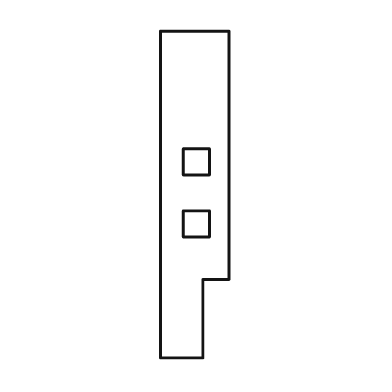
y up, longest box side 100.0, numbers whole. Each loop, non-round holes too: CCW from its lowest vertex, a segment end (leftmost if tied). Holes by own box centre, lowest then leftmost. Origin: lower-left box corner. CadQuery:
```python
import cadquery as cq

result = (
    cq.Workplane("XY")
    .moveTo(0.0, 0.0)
    .lineTo(13.0, 0.0)
    .lineTo(13.0, 24.0)
    .lineTo(21.0, 24.0)
    .lineTo(21.0, 100.0)
    .lineTo(0.0, 100.0)
    .close()
    .moveTo(7.0, 37.0)
    .lineTo(15.0, 37.0)
    .lineTo(15.0, 45.0)
    .lineTo(7.0, 45.0)
    .close()
    .moveTo(7.0, 56.0)
    .lineTo(15.0, 56.0)
    .lineTo(15.0, 64.0)
    .lineTo(7.0, 64.0)
    .close()
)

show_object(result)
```